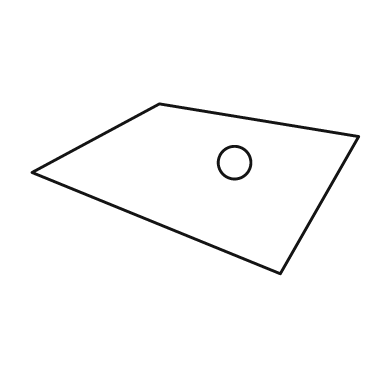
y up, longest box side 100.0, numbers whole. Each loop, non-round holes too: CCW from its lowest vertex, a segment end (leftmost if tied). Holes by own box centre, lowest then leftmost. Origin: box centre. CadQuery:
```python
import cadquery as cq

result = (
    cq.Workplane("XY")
    .moveTo(26.0, -26.0)
    .lineTo(50.0, 16.0)
    .lineTo(-11.0, 26.0)
    .lineTo(-50.0, 5.0)
    .close()
    .moveTo(12.0, 8.0)
    .circle(5.0)
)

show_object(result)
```